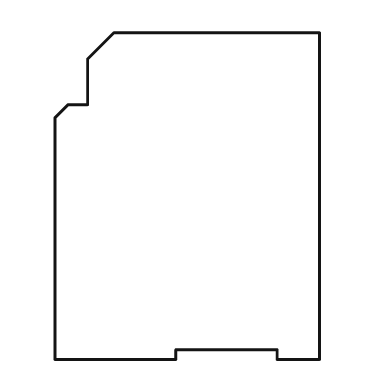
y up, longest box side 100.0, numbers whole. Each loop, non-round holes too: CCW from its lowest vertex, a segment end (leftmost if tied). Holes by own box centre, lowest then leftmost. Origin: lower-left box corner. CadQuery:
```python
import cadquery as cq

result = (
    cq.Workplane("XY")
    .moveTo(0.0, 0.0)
    .lineTo(37.0, 0.0)
    .lineTo(37.0, 3.0)
    .lineTo(68.0, 3.0)
    .lineTo(68.0, 0.0)
    .lineTo(81.0, 0.0)
    .lineTo(81.0, 100.0)
    .lineTo(18.0, 100.0)
    .lineTo(10.0, 92.0)
    .lineTo(10.0, 78.0)
    .lineTo(4.0, 78.0)
    .lineTo(0.0, 74.0)
    .close()
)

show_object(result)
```